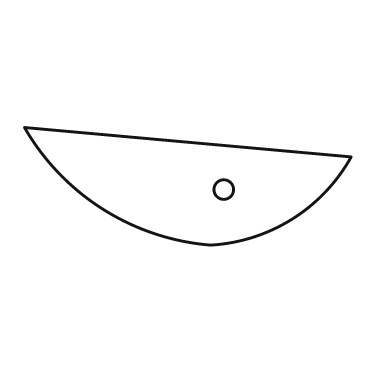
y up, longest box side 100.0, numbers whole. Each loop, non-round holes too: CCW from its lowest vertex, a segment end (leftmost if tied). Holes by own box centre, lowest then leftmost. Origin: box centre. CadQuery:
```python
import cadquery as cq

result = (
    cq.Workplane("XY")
    .moveTo(7.0, -18.0)
    .threePointArc((32.0, -10.0), (50.0, 9.0))
    .lineTo(-50.0, 18.0)
    .threePointArc((-26.0, -7.0), (7.0, -18.0))
    .close()
    .moveTo(11.0, -1.0)
    .circle(3.0)
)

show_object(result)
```